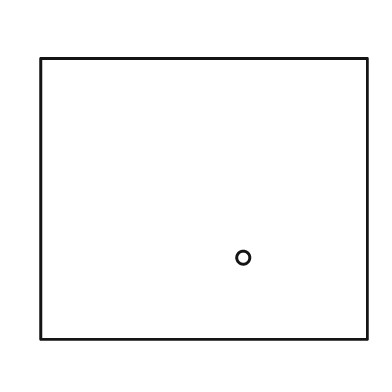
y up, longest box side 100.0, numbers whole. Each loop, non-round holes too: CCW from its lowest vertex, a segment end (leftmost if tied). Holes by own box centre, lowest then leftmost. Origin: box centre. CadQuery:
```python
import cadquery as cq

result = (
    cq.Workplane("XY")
    .moveTo(-50.0, -43.0)
    .lineTo(50.0, -43.0)
    .lineTo(50.0, 43.0)
    .lineTo(-50.0, 43.0)
    .close()
    .moveTo(12.0, -18.0)
    .circle(2.0)
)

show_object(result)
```